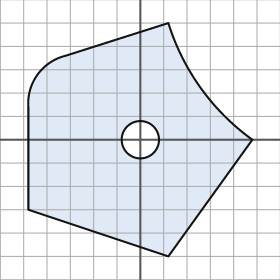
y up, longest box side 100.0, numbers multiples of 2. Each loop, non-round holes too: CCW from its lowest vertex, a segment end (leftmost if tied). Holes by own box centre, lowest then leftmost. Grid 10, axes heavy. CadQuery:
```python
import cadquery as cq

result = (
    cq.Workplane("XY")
    .moveTo(12.0, -50.0)
    .lineTo(48.0, 0.0)
    .threePointArc((26.0, 22.0), (12.0, 50.0))
    .lineTo(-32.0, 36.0)
    .threePointArc((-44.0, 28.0), (-48.0, 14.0))
    .lineTo(-48.0, -30.0)
    .close()
    .moveTo(0.0, 0.0)
    .circle(8.0)
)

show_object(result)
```